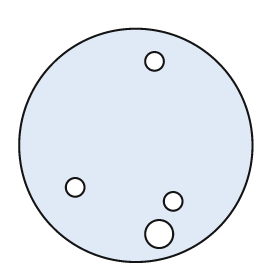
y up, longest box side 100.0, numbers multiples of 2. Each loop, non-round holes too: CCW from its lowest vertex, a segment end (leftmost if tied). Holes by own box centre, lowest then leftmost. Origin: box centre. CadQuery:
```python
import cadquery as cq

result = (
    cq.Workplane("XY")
    .moveTo(0.0, 0.0)
    .circle(50.0)
    .moveTo(10.0, -38.0)
    .circle(6.0)
    .moveTo(16.0, -24.0)
    .circle(4.0)
    .moveTo(-26.0, -18.0)
    .circle(4.0)
    .moveTo(8.0, 36.0)
    .circle(4.0)
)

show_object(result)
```